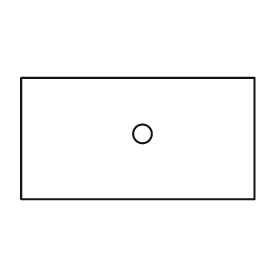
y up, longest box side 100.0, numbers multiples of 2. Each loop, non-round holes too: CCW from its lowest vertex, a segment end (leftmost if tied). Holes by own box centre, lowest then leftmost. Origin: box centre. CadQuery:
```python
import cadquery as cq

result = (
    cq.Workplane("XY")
    .moveTo(-50.0, -26.0)
    .lineTo(50.0, -26.0)
    .lineTo(50.0, 26.0)
    .lineTo(-50.0, 26.0)
    .close()
    .moveTo(2.0, 2.0)
    .circle(4.0)
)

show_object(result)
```